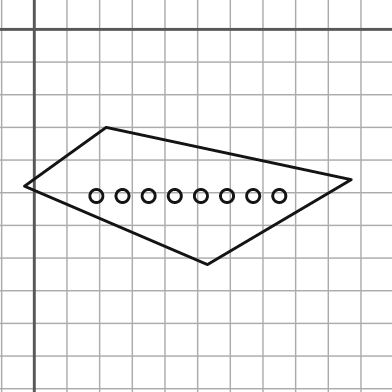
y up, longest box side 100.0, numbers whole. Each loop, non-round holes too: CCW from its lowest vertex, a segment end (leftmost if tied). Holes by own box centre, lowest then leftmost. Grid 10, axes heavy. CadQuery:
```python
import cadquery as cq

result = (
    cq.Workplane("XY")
    .moveTo(53.0, -72.0)
    .lineTo(97.0, -46.0)
    .lineTo(22.0, -30.0)
    .lineTo(-3.0, -48.0)
    .close()
    .moveTo(19.0, -51.0)
    .circle(2.0)
    .moveTo(27.0, -51.0)
    .circle(2.0)
    .moveTo(35.0, -51.0)
    .circle(2.0)
    .moveTo(43.0, -51.0)
    .circle(2.0)
    .moveTo(51.0, -51.0)
    .circle(2.0)
    .moveTo(59.0, -51.0)
    .circle(2.0)
    .moveTo(67.0, -51.0)
    .circle(2.0)
    .moveTo(75.0, -51.0)
    .circle(2.0)
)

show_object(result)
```